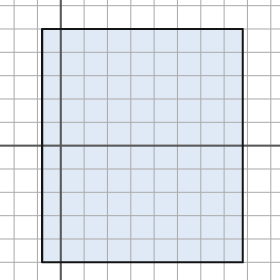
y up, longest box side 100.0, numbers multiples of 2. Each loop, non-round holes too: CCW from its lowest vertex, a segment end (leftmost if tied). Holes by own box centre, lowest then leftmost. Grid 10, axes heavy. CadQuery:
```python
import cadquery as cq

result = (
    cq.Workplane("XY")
    .moveTo(-8.0, -50.0)
    .lineTo(78.0, -50.0)
    .lineTo(78.0, 50.0)
    .lineTo(-8.0, 50.0)
    .close()
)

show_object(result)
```